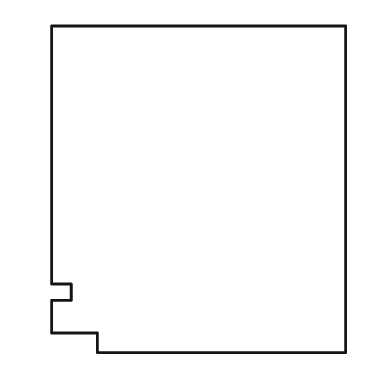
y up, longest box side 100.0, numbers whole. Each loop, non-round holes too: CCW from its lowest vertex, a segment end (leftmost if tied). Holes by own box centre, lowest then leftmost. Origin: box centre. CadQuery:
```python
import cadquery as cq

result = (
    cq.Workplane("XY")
    .moveTo(-31.0, -50.0)
    .lineTo(45.0, -50.0)
    .lineTo(45.0, 50.0)
    .lineTo(-45.0, 50.0)
    .lineTo(-45.0, -29.0)
    .lineTo(-39.0, -29.0)
    .lineTo(-39.0, -34.0)
    .lineTo(-45.0, -34.0)
    .lineTo(-45.0, -44.0)
    .lineTo(-31.0, -44.0)
    .close()
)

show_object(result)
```